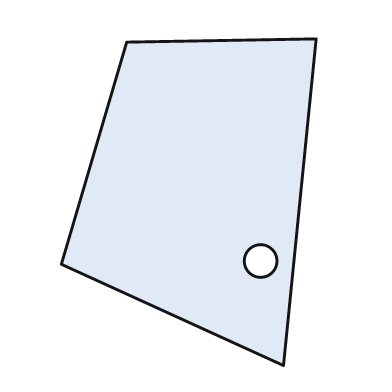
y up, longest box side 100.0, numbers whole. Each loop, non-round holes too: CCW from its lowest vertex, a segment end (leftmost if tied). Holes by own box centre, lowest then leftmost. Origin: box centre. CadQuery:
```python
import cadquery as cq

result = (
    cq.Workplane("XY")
    .moveTo(29.0, -50.0)
    .lineTo(39.0, 50.0)
    .lineTo(-19.0, 49.0)
    .lineTo(-39.0, -19.0)
    .close()
    .moveTo(22.0, -18.0)
    .circle(5.0)
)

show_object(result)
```